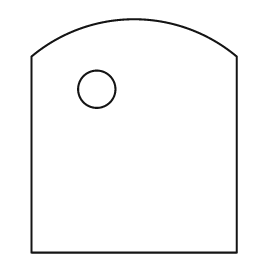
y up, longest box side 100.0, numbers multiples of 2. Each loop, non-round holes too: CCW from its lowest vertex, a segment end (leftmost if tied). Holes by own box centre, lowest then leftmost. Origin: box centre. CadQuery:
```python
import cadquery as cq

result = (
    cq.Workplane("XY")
    .moveTo(-44.0, -50.0)
    .lineTo(44.0, -50.0)
    .lineTo(44.0, 34.0)
    .threePointArc((0.0, 50.0), (-44.0, 34.0))
    .close()
    .moveTo(-16.0, 20.0)
    .circle(8.0)
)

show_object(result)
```